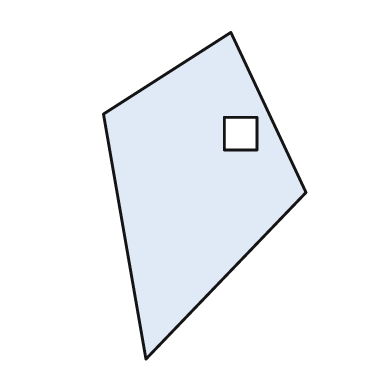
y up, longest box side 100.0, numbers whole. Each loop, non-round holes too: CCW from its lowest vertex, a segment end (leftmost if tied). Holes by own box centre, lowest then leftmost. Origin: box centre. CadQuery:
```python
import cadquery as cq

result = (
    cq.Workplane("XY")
    .moveTo(-18.0, -50.0)
    .lineTo(31.0, 1.0)
    .lineTo(8.0, 50.0)
    .lineTo(-31.0, 25.0)
    .close()
    .moveTo(6.0, 14.0)
    .lineTo(16.0, 14.0)
    .lineTo(16.0, 24.0)
    .lineTo(6.0, 24.0)
    .close()
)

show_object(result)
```